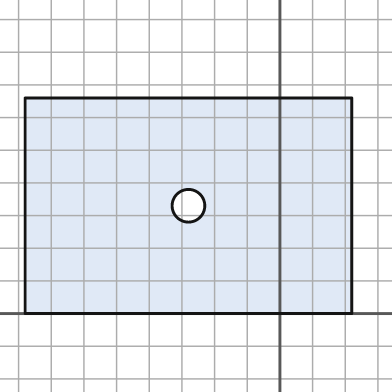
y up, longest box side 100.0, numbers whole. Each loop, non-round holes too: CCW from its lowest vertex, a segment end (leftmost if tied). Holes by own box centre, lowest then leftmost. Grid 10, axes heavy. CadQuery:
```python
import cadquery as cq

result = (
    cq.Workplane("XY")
    .moveTo(-78.0, 0.0)
    .lineTo(22.0, 0.0)
    .lineTo(22.0, 66.0)
    .lineTo(-78.0, 66.0)
    .close()
    .moveTo(-28.0, 33.0)
    .circle(5.0)
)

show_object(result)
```